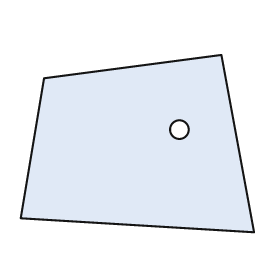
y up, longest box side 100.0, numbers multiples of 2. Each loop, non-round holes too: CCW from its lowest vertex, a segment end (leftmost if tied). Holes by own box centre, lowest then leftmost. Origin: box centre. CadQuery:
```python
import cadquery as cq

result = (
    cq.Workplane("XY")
    .moveTo(50.0, -38.0)
    .lineTo(36.0, 38.0)
    .lineTo(-40.0, 28.0)
    .lineTo(-50.0, -32.0)
    .close()
    .moveTo(18.0, 6.0)
    .circle(4.0)
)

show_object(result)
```